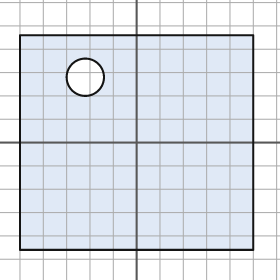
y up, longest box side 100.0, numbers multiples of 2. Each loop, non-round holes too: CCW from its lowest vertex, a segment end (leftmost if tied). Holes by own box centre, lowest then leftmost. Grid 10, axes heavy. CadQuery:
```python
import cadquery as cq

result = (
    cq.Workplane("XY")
    .moveTo(-50.0, -46.0)
    .lineTo(50.0, -46.0)
    .lineTo(50.0, 46.0)
    .lineTo(-50.0, 46.0)
    .close()
    .moveTo(-22.0, 28.0)
    .circle(8.0)
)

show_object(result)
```